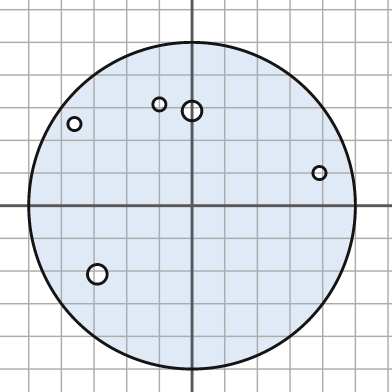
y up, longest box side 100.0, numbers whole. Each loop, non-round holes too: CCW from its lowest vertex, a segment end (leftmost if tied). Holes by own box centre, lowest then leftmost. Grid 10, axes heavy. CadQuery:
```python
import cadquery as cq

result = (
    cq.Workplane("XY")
    .moveTo(0.0, 0.0)
    .circle(50.0)
    .moveTo(-29.0, -21.0)
    .circle(3.0)
    .moveTo(39.0, 10.0)
    .circle(2.0)
    .moveTo(-36.0, 25.0)
    .circle(2.0)
    .moveTo(0.0, 29.0)
    .circle(3.0)
    .moveTo(-10.0, 31.0)
    .circle(2.0)
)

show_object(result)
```